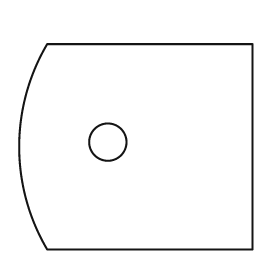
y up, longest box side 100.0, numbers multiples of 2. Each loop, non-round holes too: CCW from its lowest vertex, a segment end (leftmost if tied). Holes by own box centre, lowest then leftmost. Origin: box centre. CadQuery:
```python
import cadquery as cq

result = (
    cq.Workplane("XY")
    .moveTo(-38.0, -44.0)
    .lineTo(50.0, -44.0)
    .lineTo(50.0, 44.0)
    .lineTo(-38.0, 44.0)
    .threePointArc((-50.0, 0.0), (-38.0, -44.0))
    .close()
    .moveTo(-12.0, 2.0)
    .circle(8.0)
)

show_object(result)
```